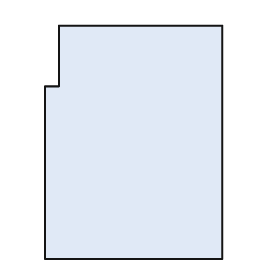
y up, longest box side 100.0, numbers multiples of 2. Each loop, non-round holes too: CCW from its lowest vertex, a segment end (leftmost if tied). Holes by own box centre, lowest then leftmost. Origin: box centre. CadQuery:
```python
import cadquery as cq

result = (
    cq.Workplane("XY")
    .moveTo(-38.0, -50.0)
    .lineTo(38.0, -50.0)
    .lineTo(38.0, 50.0)
    .lineTo(-32.0, 50.0)
    .lineTo(-32.0, 24.0)
    .lineTo(-38.0, 24.0)
    .close()
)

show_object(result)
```